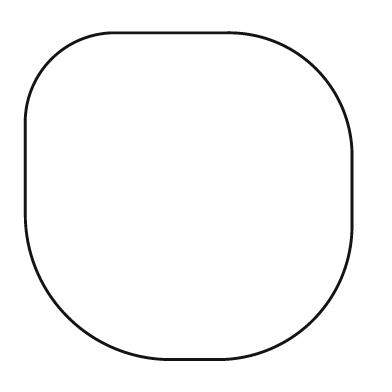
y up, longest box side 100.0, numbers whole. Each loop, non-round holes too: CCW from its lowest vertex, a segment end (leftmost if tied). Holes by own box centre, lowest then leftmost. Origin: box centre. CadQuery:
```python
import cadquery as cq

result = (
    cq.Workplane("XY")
    .moveTo(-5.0, -50.0)
    .lineTo(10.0, -50.0)
    .threePointArc((38.0, -38.0), (50.0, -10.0))
    .lineTo(50.0, 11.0)
    .threePointArc((39.0, 39.0), (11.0, 50.0))
    .lineTo(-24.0, 50.0)
    .threePointArc((-42.0, 42.0), (-50.0, 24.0))
    .lineTo(-50.0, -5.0)
    .threePointArc((-37.0, -37.0), (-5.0, -50.0))
    .close()
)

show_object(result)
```